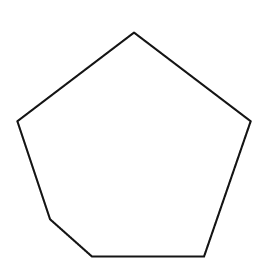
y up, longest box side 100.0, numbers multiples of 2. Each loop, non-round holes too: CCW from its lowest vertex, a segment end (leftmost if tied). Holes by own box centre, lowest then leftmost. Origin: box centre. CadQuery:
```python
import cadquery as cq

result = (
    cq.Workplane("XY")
    .moveTo(-18.0, -48.0)
    .lineTo(30.0, -48.0)
    .lineTo(50.0, 10.0)
    .lineTo(0.0, 48.0)
    .lineTo(-50.0, 10.0)
    .lineTo(-36.0, -32.0)
    .close()
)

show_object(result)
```